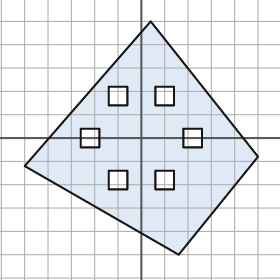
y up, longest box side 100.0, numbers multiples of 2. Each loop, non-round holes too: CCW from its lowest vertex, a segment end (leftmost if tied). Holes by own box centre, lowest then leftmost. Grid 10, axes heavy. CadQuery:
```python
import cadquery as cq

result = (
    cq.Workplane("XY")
    .moveTo(16.0, -50.0)
    .lineTo(50.0, -8.0)
    .lineTo(4.0, 50.0)
    .lineTo(-50.0, -12.0)
    .close()
    .moveTo(-14.0, -22.0)
    .lineTo(-6.0, -22.0)
    .lineTo(-6.0, -14.0)
    .lineTo(-14.0, -14.0)
    .close()
    .moveTo(6.0, -22.0)
    .lineTo(14.0, -22.0)
    .lineTo(14.0, -14.0)
    .lineTo(6.0, -14.0)
    .close()
    .moveTo(-26.0, -4.0)
    .lineTo(-18.0, -4.0)
    .lineTo(-18.0, 4.0)
    .lineTo(-26.0, 4.0)
    .close()
    .moveTo(18.0, -4.0)
    .lineTo(26.0, -4.0)
    .lineTo(26.0, 4.0)
    .lineTo(18.0, 4.0)
    .close()
    .moveTo(-14.0, 14.0)
    .lineTo(-6.0, 14.0)
    .lineTo(-6.0, 22.0)
    .lineTo(-14.0, 22.0)
    .close()
    .moveTo(6.0, 14.0)
    .lineTo(14.0, 14.0)
    .lineTo(14.0, 22.0)
    .lineTo(6.0, 22.0)
    .close()
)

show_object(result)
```